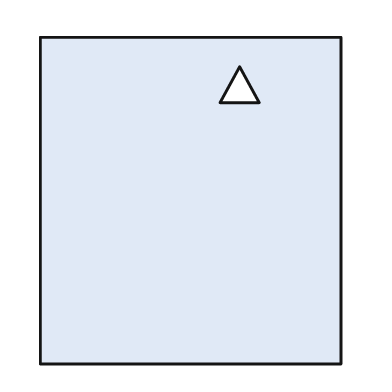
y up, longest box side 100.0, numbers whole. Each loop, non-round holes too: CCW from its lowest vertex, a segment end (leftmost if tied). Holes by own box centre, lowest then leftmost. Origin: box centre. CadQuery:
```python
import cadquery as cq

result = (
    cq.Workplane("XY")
    .moveTo(-46.0, -50.0)
    .lineTo(46.0, -50.0)
    .lineTo(46.0, 50.0)
    .lineTo(-46.0, 50.0)
    .close()
    .moveTo(9.0, 30.0)
    .lineTo(21.0, 30.0)
    .lineTo(15.0, 41.0)
    .close()
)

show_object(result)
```